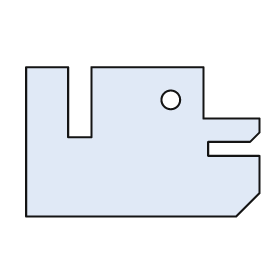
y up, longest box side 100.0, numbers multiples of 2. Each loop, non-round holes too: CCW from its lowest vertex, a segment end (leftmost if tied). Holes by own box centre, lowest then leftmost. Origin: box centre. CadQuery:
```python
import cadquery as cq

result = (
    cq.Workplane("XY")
    .moveTo(-50.0, -32.0)
    .lineTo(40.0, -32.0)
    .lineTo(50.0, -22.0)
    .lineTo(50.0, -6.0)
    .lineTo(28.0, -6.0)
    .lineTo(28.0, 0.0)
    .lineTo(46.0, 0.0)
    .lineTo(50.0, 4.0)
    .lineTo(50.0, 10.0)
    .lineTo(26.0, 10.0)
    .lineTo(26.0, 32.0)
    .lineTo(-22.0, 32.0)
    .lineTo(-22.0, 2.0)
    .lineTo(-32.0, 2.0)
    .lineTo(-32.0, 32.0)
    .lineTo(-50.0, 32.0)
    .close()
    .moveTo(12.0, 18.0)
    .circle(4.0)
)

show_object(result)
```